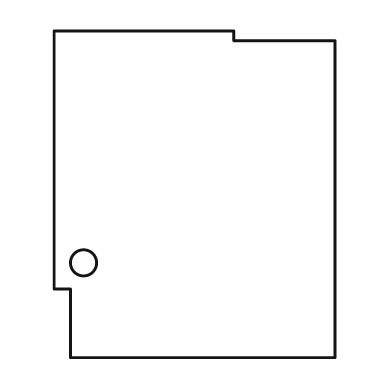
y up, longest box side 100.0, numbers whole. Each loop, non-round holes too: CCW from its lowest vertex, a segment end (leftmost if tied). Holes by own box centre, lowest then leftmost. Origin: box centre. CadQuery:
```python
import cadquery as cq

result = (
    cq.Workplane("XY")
    .moveTo(-38.0, -50.0)
    .lineTo(43.0, -50.0)
    .lineTo(43.0, 47.0)
    .lineTo(12.0, 47.0)
    .lineTo(12.0, 50.0)
    .lineTo(-43.0, 50.0)
    .lineTo(-43.0, -29.0)
    .lineTo(-38.0, -29.0)
    .close()
    .moveTo(-34.0, -21.0)
    .circle(4.0)
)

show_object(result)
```